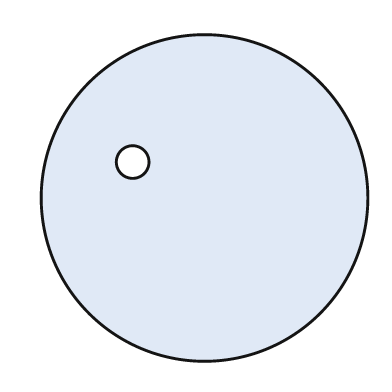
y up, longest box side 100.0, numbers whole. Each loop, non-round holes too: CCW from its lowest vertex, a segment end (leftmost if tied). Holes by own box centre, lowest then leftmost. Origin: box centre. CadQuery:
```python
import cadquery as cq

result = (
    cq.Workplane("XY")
    .moveTo(0.0, 0.0)
    .circle(50.0)
    .moveTo(-22.0, 11.0)
    .circle(5.0)
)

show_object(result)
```